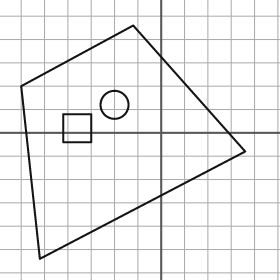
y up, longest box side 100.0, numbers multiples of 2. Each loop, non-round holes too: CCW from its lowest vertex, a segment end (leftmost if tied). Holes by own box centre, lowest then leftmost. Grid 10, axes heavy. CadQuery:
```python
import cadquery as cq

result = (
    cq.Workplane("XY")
    .moveTo(-52.0, -54.0)
    .lineTo(36.0, -8.0)
    .lineTo(-12.0, 46.0)
    .lineTo(-60.0, 20.0)
    .close()
    .moveTo(-42.0, -4.0)
    .lineTo(-30.0, -4.0)
    .lineTo(-30.0, 8.0)
    .lineTo(-42.0, 8.0)
    .close()
    .moveTo(-20.0, 12.0)
    .circle(6.0)
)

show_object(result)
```